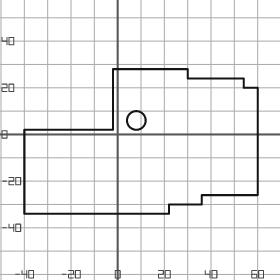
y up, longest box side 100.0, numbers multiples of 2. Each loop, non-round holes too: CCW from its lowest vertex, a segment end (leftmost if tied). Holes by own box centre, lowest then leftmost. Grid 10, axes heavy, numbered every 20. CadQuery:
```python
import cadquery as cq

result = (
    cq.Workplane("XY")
    .moveTo(-40.0, -34.0)
    .lineTo(22.0, -34.0)
    .lineTo(22.0, -30.0)
    .lineTo(36.0, -30.0)
    .lineTo(36.0, -26.0)
    .lineTo(60.0, -26.0)
    .lineTo(60.0, 20.0)
    .lineTo(54.0, 20.0)
    .lineTo(54.0, 24.0)
    .lineTo(30.0, 24.0)
    .lineTo(30.0, 28.0)
    .lineTo(-2.0, 28.0)
    .lineTo(-2.0, 2.0)
    .lineTo(-40.0, 2.0)
    .close()
    .moveTo(8.0, 6.0)
    .circle(4.0)
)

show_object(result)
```